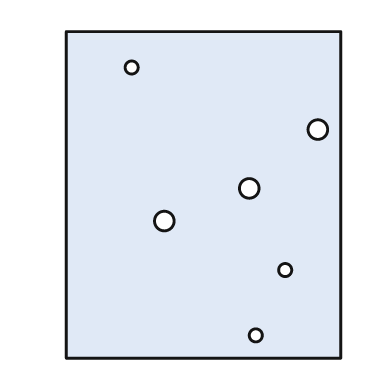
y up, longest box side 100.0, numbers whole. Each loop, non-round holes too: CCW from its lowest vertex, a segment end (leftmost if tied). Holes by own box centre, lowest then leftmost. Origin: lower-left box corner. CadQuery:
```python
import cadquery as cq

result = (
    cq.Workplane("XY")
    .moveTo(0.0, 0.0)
    .lineTo(84.0, 0.0)
    .lineTo(84.0, 100.0)
    .lineTo(0.0, 100.0)
    .close()
    .moveTo(58.0, 7.0)
    .circle(2.0)
    .moveTo(67.0, 27.0)
    .circle(2.0)
    .moveTo(30.0, 42.0)
    .circle(3.0)
    .moveTo(56.0, 52.0)
    .circle(3.0)
    .moveTo(77.0, 70.0)
    .circle(3.0)
    .moveTo(20.0, 89.0)
    .circle(2.0)
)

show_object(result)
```